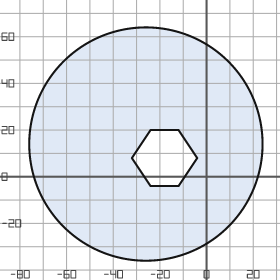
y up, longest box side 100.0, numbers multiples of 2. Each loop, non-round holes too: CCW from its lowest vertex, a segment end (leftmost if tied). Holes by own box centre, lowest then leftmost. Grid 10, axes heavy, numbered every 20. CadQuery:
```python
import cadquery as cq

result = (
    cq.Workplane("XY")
    .moveTo(-26.0, 14.0)
    .circle(50.0)
    .moveTo(-24.0, -4.0)
    .lineTo(-12.0, -4.0)
    .lineTo(-4.0, 8.0)
    .lineTo(-12.0, 20.0)
    .lineTo(-24.0, 20.0)
    .lineTo(-32.0, 8.0)
    .close()
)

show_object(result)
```